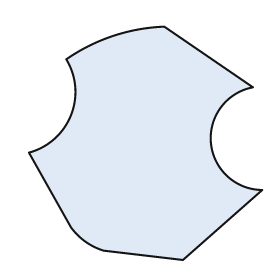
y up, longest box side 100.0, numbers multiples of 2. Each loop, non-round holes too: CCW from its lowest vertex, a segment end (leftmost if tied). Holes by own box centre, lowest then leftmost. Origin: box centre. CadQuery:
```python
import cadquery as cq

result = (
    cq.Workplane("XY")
    .moveTo(16.0, -50.0)
    .lineTo(50.0, -20.0)
    .threePointArc((28.0, 0.0), (46.0, 24.0))
    .lineTo(8.0, 50.0)
    .threePointArc((-14.0, 46.0), (-34.0, 36.0))
    .threePointArc((-32.0, 12.0), (-50.0, -4.0))
    .lineTo(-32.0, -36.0)
    .threePointArc((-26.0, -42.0), (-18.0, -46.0))
    .close()
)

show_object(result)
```